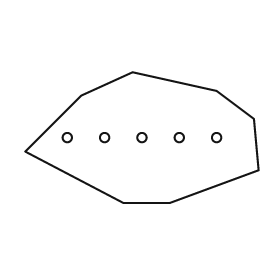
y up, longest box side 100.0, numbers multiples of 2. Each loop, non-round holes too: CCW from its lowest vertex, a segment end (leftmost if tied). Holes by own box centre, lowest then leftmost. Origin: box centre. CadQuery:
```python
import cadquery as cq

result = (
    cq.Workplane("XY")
    .moveTo(-8.0, -28.0)
    .lineTo(12.0, -28.0)
    .lineTo(50.0, -14.0)
    .lineTo(48.0, 8.0)
    .lineTo(32.0, 20.0)
    .lineTo(-4.0, 28.0)
    .lineTo(-26.0, 18.0)
    .lineTo(-50.0, -6.0)
    .close()
    .moveTo(-32.0, 0.0)
    .circle(2.0)
    .moveTo(-16.0, 0.0)
    .circle(2.0)
    .moveTo(0.0, 0.0)
    .circle(2.0)
    .moveTo(16.0, 0.0)
    .circle(2.0)
    .moveTo(32.0, 0.0)
    .circle(2.0)
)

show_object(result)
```